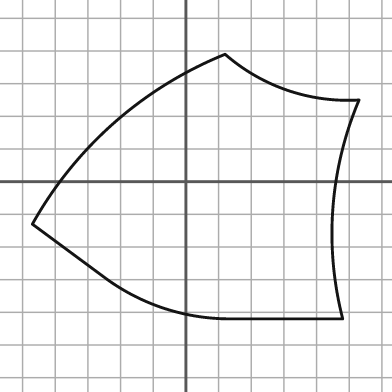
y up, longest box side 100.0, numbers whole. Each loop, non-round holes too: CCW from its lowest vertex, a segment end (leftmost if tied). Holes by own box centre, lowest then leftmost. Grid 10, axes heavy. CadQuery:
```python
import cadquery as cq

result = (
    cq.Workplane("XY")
    .moveTo(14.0, -42.0)
    .lineTo(48.0, -42.0)
    .threePointArc((45.0, -8.0), (53.0, 25.0))
    .threePointArc((31.0, 28.0), (12.0, 39.0))
    .threePointArc((-22.0, 18.0), (-47.0, -13.0))
    .lineTo(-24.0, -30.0)
    .threePointArc((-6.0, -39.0), (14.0, -42.0))
    .close()
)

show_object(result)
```